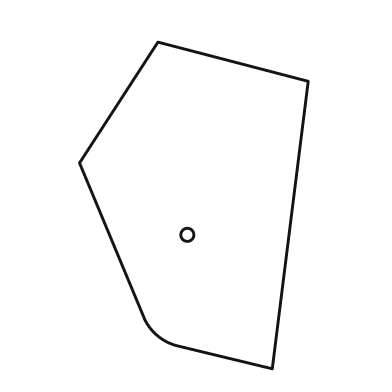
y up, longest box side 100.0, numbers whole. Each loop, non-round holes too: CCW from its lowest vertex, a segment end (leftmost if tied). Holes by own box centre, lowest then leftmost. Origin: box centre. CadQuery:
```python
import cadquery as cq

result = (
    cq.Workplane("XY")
    .moveTo(24.0, -50.0)
    .lineTo(35.0, 38.0)
    .lineTo(-11.0, 50.0)
    .lineTo(-35.0, 13.0)
    .lineTo(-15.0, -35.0)
    .threePointArc((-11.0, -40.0), (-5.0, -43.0))
    .close()
    .moveTo(-2.0, -9.0)
    .circle(2.0)
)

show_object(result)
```